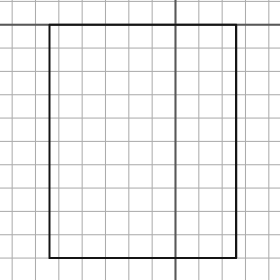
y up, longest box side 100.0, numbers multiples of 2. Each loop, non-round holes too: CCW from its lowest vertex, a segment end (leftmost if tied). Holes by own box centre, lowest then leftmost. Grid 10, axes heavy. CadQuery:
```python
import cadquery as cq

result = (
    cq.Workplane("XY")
    .moveTo(-54.0, -100.0)
    .lineTo(26.0, -100.0)
    .lineTo(26.0, 0.0)
    .lineTo(-54.0, 0.0)
    .close()
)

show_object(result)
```